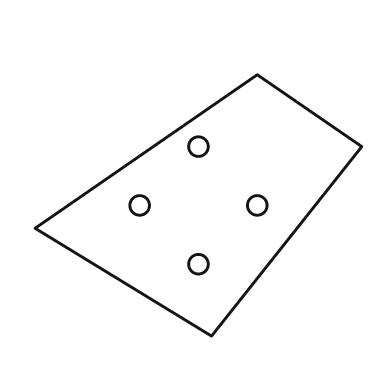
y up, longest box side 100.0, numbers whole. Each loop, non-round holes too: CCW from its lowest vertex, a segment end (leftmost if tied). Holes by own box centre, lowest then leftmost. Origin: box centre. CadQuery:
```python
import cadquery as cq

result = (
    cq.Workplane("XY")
    .moveTo(4.0, -40.0)
    .lineTo(50.0, 18.0)
    .lineTo(18.0, 40.0)
    .lineTo(-50.0, -7.0)
    .close()
    .moveTo(0.0, -18.0)
    .circle(3.0)
    .moveTo(-18.0, 0.0)
    .circle(3.0)
    .moveTo(18.0, 0.0)
    .circle(3.0)
    .moveTo(0.0, 18.0)
    .circle(3.0)
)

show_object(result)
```